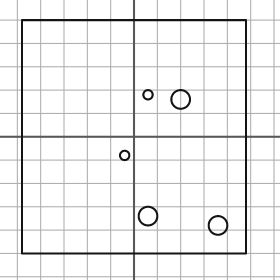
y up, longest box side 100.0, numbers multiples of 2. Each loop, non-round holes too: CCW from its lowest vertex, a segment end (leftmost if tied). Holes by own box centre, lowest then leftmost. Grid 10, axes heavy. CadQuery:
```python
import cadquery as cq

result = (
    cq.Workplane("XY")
    .moveTo(-48.0, -50.0)
    .lineTo(48.0, -50.0)
    .lineTo(48.0, 50.0)
    .lineTo(-48.0, 50.0)
    .close()
    .moveTo(36.0, -38.0)
    .circle(4.0)
    .moveTo(6.0, -34.0)
    .circle(4.0)
    .moveTo(-4.0, -8.0)
    .circle(2.0)
    .moveTo(20.0, 16.0)
    .circle(4.0)
    .moveTo(6.0, 18.0)
    .circle(2.0)
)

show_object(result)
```